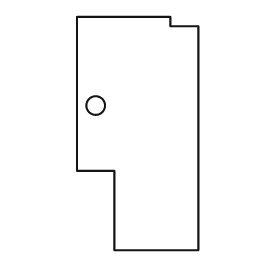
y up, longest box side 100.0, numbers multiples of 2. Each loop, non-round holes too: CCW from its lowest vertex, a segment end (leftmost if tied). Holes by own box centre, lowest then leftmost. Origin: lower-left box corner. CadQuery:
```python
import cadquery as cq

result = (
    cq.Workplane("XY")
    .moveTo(16.0, 0.0)
    .lineTo(52.0, 0.0)
    .lineTo(52.0, 96.0)
    .lineTo(40.0, 96.0)
    .lineTo(40.0, 100.0)
    .lineTo(0.0, 100.0)
    .lineTo(0.0, 34.0)
    .lineTo(16.0, 34.0)
    .close()
    .moveTo(8.0, 62.0)
    .circle(4.0)
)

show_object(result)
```